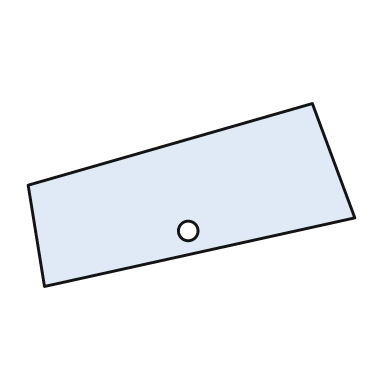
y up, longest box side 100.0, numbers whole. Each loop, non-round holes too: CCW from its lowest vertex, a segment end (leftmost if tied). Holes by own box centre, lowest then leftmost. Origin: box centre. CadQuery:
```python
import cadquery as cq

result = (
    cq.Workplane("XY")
    .moveTo(-45.0, -28.0)
    .lineTo(50.0, -7.0)
    .lineTo(37.0, 28.0)
    .lineTo(-50.0, 3.0)
    .close()
    .moveTo(-1.0, -11.0)
    .circle(3.0)
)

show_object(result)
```